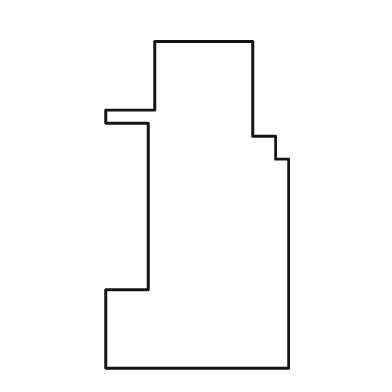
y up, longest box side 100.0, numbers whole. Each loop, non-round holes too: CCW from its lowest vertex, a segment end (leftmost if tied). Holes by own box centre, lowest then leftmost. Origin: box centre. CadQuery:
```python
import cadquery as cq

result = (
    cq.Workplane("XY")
    .moveTo(-28.0, -50.0)
    .lineTo(28.0, -50.0)
    .lineTo(28.0, 14.0)
    .lineTo(24.0, 14.0)
    .lineTo(24.0, 21.0)
    .lineTo(17.0, 21.0)
    .lineTo(17.0, 50.0)
    .lineTo(-13.0, 50.0)
    .lineTo(-13.0, 29.0)
    .lineTo(-28.0, 29.0)
    .lineTo(-28.0, 25.0)
    .lineTo(-15.0, 25.0)
    .lineTo(-15.0, -26.0)
    .lineTo(-28.0, -26.0)
    .close()
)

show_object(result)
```